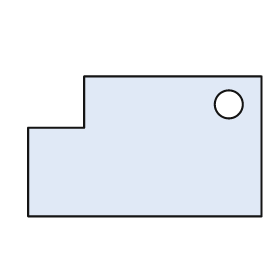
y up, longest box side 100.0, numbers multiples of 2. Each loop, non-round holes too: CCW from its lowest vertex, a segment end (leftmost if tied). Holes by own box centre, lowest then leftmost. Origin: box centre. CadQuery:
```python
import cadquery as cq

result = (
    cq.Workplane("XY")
    .moveTo(-50.0, -30.0)
    .lineTo(50.0, -30.0)
    .lineTo(50.0, 30.0)
    .lineTo(-26.0, 30.0)
    .lineTo(-26.0, 8.0)
    .lineTo(-50.0, 8.0)
    .close()
    .moveTo(36.0, 18.0)
    .circle(6.0)
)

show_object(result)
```